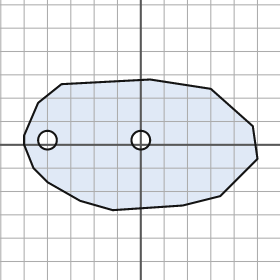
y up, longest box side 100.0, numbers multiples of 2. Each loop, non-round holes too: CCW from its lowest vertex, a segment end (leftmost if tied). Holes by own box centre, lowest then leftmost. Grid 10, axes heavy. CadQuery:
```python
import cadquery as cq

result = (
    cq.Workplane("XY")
    .moveTo(-12.0, -28.0)
    .lineTo(18.0, -26.0)
    .lineTo(34.0, -22.0)
    .lineTo(50.0, -6.0)
    .lineTo(48.0, 8.0)
    .lineTo(30.0, 24.0)
    .lineTo(4.0, 28.0)
    .lineTo(-34.0, 26.0)
    .lineTo(-44.0, 18.0)
    .lineTo(-50.0, 4.0)
    .lineTo(-50.0, 0.0)
    .lineTo(-46.0, -10.0)
    .lineTo(-40.0, -16.0)
    .lineTo(-26.0, -24.0)
    .close()
    .moveTo(-40.0, 2.0)
    .circle(4.0)
    .moveTo(0.0, 2.0)
    .circle(4.0)
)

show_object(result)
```